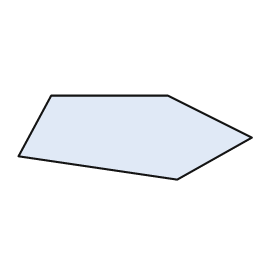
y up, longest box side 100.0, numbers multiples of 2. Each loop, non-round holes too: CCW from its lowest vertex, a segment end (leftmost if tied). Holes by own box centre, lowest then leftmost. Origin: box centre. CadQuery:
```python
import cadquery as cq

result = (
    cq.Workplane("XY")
    .moveTo(18.0, -18.0)
    .lineTo(50.0, 0.0)
    .lineTo(14.0, 18.0)
    .lineTo(-36.0, 18.0)
    .lineTo(-50.0, -8.0)
    .close()
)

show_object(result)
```